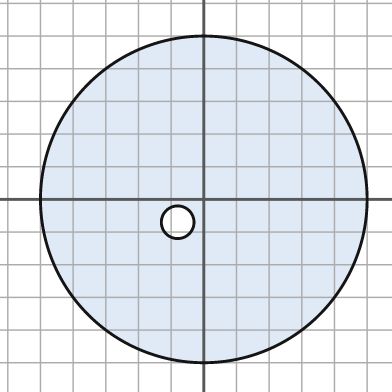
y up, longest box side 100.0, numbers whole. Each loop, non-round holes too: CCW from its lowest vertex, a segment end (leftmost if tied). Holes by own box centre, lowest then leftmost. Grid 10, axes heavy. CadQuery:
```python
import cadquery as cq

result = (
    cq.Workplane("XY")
    .moveTo(0.0, 0.0)
    .circle(50.0)
    .moveTo(-8.0, -7.0)
    .circle(5.0)
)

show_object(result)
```